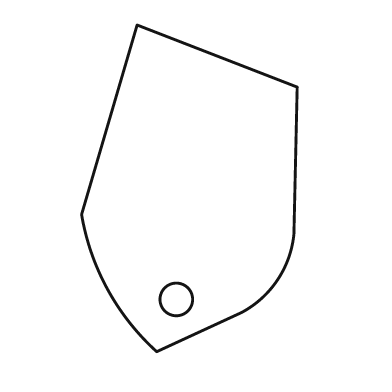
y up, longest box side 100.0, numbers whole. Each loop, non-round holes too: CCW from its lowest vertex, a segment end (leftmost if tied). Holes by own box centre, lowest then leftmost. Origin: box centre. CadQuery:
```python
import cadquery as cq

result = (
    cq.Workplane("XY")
    .moveTo(-10.0, -50.0)
    .lineTo(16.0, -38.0)
    .threePointArc((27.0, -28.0), (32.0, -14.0))
    .lineTo(33.0, 31.0)
    .lineTo(-16.0, 50.0)
    .lineTo(-33.0, -8.0)
    .threePointArc((-25.0, -31.0), (-10.0, -50.0))
    .close()
    .moveTo(-4.0, -34.0)
    .circle(5.0)
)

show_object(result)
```